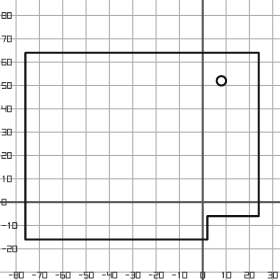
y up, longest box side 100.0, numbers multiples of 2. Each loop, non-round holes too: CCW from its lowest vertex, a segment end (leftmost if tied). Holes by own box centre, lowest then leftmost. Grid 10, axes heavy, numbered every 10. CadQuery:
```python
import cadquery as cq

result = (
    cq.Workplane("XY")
    .moveTo(-76.0, -16.0)
    .lineTo(2.0, -16.0)
    .lineTo(2.0, -6.0)
    .lineTo(24.0, -6.0)
    .lineTo(24.0, 64.0)
    .lineTo(-76.0, 64.0)
    .close()
    .moveTo(8.0, 52.0)
    .circle(2.0)
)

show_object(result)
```